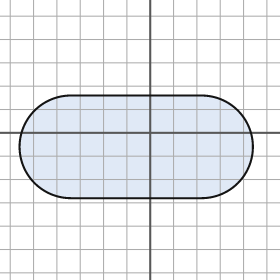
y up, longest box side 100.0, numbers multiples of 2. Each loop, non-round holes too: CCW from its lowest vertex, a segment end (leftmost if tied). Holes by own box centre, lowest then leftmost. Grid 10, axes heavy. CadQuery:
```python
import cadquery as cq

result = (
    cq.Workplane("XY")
    .moveTo(-34.0, -28.0)
    .lineTo(22.0, -28.0)
    .threePointArc((44.0, -6.0), (22.0, 16.0))
    .lineTo(-34.0, 16.0)
    .threePointArc((-56.0, -6.0), (-34.0, -28.0))
    .close()
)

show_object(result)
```